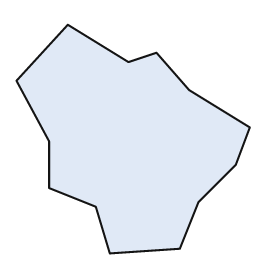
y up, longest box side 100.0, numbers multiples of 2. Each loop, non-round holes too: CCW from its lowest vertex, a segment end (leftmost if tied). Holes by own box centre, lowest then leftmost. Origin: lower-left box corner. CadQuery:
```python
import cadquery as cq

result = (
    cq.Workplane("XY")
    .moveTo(40.0, 0.0)
    .lineTo(70.0, 2.0)
    .lineTo(78.0, 22.0)
    .lineTo(94.0, 38.0)
    .lineTo(100.0, 54.0)
    .lineTo(74.0, 70.0)
    .lineTo(60.0, 86.0)
    .lineTo(48.0, 82.0)
    .lineTo(22.0, 98.0)
    .lineTo(0.0, 74.0)
    .lineTo(14.0, 48.0)
    .lineTo(14.0, 28.0)
    .lineTo(34.0, 20.0)
    .close()
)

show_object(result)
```